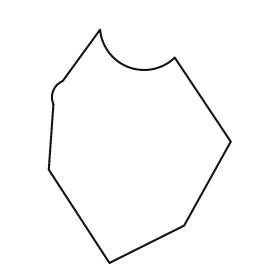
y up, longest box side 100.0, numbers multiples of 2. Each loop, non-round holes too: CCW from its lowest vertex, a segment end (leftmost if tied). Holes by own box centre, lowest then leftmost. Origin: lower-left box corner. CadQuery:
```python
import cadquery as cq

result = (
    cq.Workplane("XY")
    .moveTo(26.0, 0.0)
    .lineTo(58.0, 16.0)
    .lineTo(78.0, 52.0)
    .lineTo(54.0, 88.0)
    .threePointArc((34.0, 84.0), (22.0, 100.0))
    .lineTo(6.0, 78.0)
    .threePointArc((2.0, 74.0), (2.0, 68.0))
    .lineTo(0.0, 40.0)
    .close()
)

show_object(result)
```